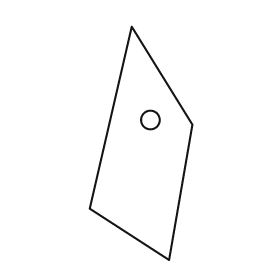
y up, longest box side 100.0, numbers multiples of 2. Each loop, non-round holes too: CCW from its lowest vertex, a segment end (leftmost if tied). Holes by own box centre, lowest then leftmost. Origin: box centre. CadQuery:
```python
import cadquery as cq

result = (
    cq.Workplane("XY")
    .moveTo(12.0, -50.0)
    .lineTo(22.0, 8.0)
    .lineTo(-4.0, 50.0)
    .lineTo(-22.0, -28.0)
    .close()
    .moveTo(4.0, 10.0)
    .circle(4.0)
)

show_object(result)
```